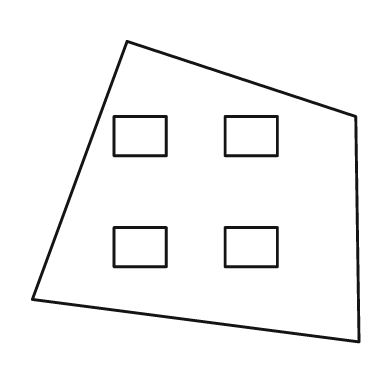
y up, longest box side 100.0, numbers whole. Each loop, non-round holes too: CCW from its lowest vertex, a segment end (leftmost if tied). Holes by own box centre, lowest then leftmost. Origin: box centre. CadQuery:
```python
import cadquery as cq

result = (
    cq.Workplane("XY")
    .moveTo(50.0, -46.0)
    .lineTo(49.0, 23.0)
    .lineTo(-21.0, 46.0)
    .lineTo(-50.0, -33.0)
    .close()
    .moveTo(-25.0, -23.0)
    .lineTo(-9.0, -23.0)
    .lineTo(-9.0, -11.0)
    .lineTo(-25.0, -11.0)
    .close()
    .moveTo(9.0, -23.0)
    .lineTo(25.0, -23.0)
    .lineTo(25.0, -11.0)
    .lineTo(9.0, -11.0)
    .close()
    .moveTo(-25.0, 11.0)
    .lineTo(-9.0, 11.0)
    .lineTo(-9.0, 23.0)
    .lineTo(-25.0, 23.0)
    .close()
    .moveTo(9.0, 11.0)
    .lineTo(25.0, 11.0)
    .lineTo(25.0, 23.0)
    .lineTo(9.0, 23.0)
    .close()
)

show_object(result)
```